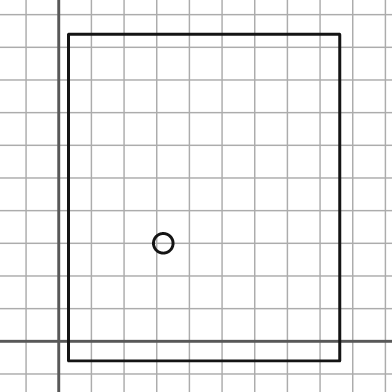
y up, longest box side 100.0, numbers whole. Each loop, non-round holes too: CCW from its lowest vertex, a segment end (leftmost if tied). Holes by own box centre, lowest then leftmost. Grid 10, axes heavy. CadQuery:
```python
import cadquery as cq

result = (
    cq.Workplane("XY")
    .moveTo(3.0, -6.0)
    .lineTo(86.0, -6.0)
    .lineTo(86.0, 94.0)
    .lineTo(3.0, 94.0)
    .close()
    .moveTo(32.0, 30.0)
    .circle(3.0)
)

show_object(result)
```